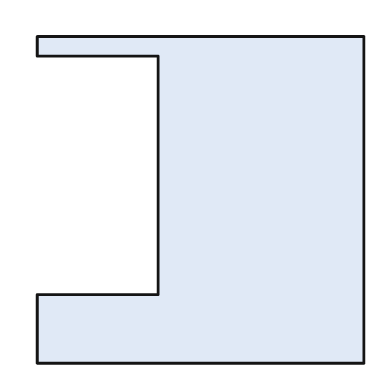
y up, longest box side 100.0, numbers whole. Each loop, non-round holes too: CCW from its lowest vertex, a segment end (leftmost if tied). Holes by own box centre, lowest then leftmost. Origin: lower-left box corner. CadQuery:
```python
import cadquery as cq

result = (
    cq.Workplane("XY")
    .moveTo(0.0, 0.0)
    .lineTo(100.0, 0.0)
    .lineTo(100.0, 100.0)
    .lineTo(0.0, 100.0)
    .lineTo(0.0, 94.0)
    .lineTo(37.0, 94.0)
    .lineTo(37.0, 21.0)
    .lineTo(0.0, 21.0)
    .close()
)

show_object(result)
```